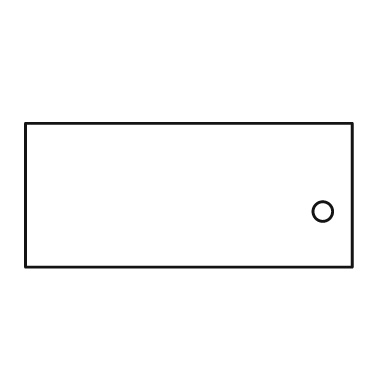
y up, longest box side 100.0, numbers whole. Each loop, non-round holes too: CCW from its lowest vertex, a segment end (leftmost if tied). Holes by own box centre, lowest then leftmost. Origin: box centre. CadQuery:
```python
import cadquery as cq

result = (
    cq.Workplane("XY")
    .moveTo(-50.0, -22.0)
    .lineTo(50.0, -22.0)
    .lineTo(50.0, 22.0)
    .lineTo(-50.0, 22.0)
    .close()
    .moveTo(41.0, -5.0)
    .circle(3.0)
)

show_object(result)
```